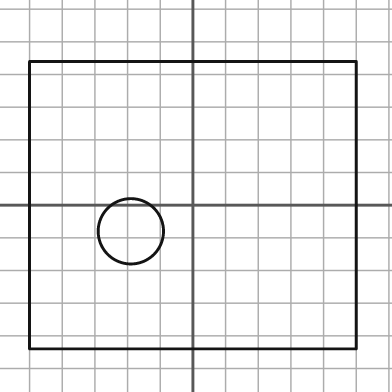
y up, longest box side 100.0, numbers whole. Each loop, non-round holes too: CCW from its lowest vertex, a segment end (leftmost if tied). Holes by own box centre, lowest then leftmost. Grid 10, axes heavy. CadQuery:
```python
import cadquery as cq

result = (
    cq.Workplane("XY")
    .moveTo(-50.0, -44.0)
    .lineTo(50.0, -44.0)
    .lineTo(50.0, 44.0)
    .lineTo(-50.0, 44.0)
    .close()
    .moveTo(-19.0, -8.0)
    .circle(10.0)
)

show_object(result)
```